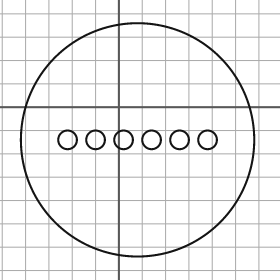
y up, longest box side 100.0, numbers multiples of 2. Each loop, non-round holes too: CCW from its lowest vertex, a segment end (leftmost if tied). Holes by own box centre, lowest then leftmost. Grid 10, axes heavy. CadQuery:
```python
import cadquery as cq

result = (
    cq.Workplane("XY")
    .moveTo(8.0, -14.0)
    .circle(50.0)
    .moveTo(-22.0, -14.0)
    .circle(4.0)
    .moveTo(-10.0, -14.0)
    .circle(4.0)
    .moveTo(2.0, -14.0)
    .circle(4.0)
    .moveTo(14.0, -14.0)
    .circle(4.0)
    .moveTo(26.0, -14.0)
    .circle(4.0)
    .moveTo(38.0, -14.0)
    .circle(4.0)
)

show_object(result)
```